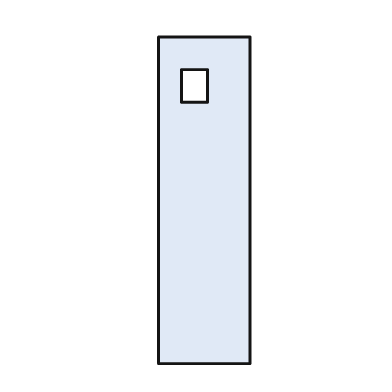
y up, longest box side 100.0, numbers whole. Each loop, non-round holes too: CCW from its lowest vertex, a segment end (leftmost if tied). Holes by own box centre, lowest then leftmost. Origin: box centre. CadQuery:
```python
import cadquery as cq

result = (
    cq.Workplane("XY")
    .moveTo(-14.0, -50.0)
    .lineTo(14.0, -50.0)
    .lineTo(14.0, 50.0)
    .lineTo(-14.0, 50.0)
    .close()
    .moveTo(-7.0, 30.0)
    .lineTo(1.0, 30.0)
    .lineTo(1.0, 40.0)
    .lineTo(-7.0, 40.0)
    .close()
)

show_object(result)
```